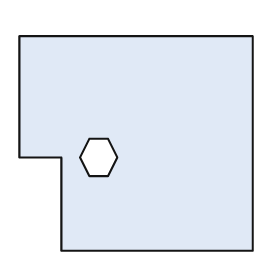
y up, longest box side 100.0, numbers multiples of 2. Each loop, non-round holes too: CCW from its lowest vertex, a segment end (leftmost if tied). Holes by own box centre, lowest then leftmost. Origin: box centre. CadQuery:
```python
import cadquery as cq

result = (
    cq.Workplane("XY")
    .moveTo(-32.0, -46.0)
    .lineTo(50.0, -46.0)
    .lineTo(50.0, 46.0)
    .lineTo(-50.0, 46.0)
    .lineTo(-50.0, -6.0)
    .lineTo(-32.0, -6.0)
    .close()
    .moveTo(-20.0, -14.0)
    .lineTo(-12.0, -14.0)
    .lineTo(-8.0, -6.0)
    .lineTo(-12.0, 2.0)
    .lineTo(-20.0, 2.0)
    .lineTo(-24.0, -6.0)
    .close()
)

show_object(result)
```